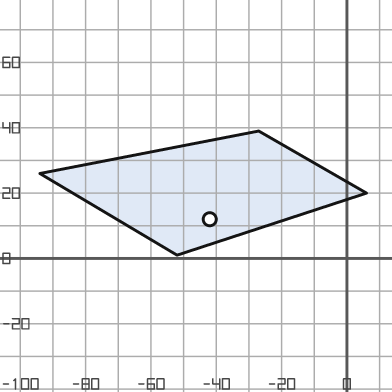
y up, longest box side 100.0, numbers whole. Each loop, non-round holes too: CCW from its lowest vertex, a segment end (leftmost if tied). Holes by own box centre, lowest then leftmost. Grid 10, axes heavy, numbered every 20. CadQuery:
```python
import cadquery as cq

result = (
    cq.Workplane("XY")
    .moveTo(-52.0, 1.0)
    .lineTo(6.0, 20.0)
    .lineTo(-27.0, 39.0)
    .lineTo(-94.0, 26.0)
    .close()
    .moveTo(-42.0, 12.0)
    .circle(2.0)
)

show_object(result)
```